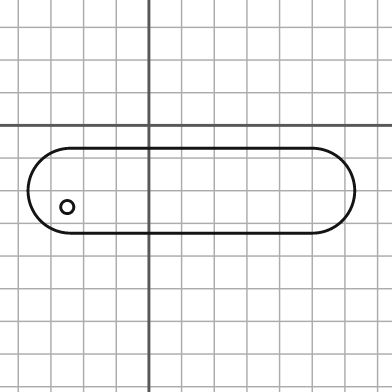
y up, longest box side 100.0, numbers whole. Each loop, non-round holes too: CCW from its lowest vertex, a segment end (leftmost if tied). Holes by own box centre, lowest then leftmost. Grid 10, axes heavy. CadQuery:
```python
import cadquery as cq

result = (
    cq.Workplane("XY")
    .moveTo(-24.0, -33.0)
    .lineTo(50.0, -33.0)
    .threePointArc((63.0, -20.0), (50.0, -7.0))
    .lineTo(-24.0, -7.0)
    .threePointArc((-37.0, -20.0), (-24.0, -33.0))
    .close()
    .moveTo(-25.0, -25.0)
    .circle(2.0)
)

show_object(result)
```